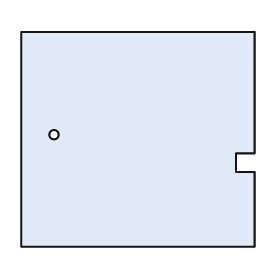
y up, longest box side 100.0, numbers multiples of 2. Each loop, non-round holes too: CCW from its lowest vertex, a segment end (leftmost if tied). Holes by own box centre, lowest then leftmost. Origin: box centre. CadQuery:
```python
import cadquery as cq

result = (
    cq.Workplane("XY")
    .moveTo(-50.0, -46.0)
    .lineTo(50.0, -46.0)
    .lineTo(50.0, -14.0)
    .lineTo(42.0, -14.0)
    .lineTo(42.0, -6.0)
    .lineTo(50.0, -6.0)
    .lineTo(50.0, 46.0)
    .lineTo(-50.0, 46.0)
    .close()
    .moveTo(-36.0, 2.0)
    .circle(2.0)
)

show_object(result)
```